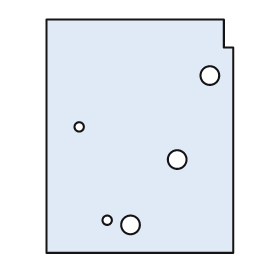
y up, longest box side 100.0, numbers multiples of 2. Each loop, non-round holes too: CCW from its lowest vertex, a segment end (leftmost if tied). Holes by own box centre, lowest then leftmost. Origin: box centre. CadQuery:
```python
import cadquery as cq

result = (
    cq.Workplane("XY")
    .moveTo(-40.0, -50.0)
    .lineTo(40.0, -50.0)
    .lineTo(40.0, 38.0)
    .lineTo(36.0, 38.0)
    .lineTo(36.0, 50.0)
    .lineTo(-40.0, 50.0)
    .close()
    .moveTo(-4.0, -38.0)
    .circle(4.0)
    .moveTo(-14.0, -36.0)
    .circle(2.0)
    .moveTo(16.0, -10.0)
    .circle(4.0)
    .moveTo(-26.0, 4.0)
    .circle(2.0)
    .moveTo(30.0, 26.0)
    .circle(4.0)
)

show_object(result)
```